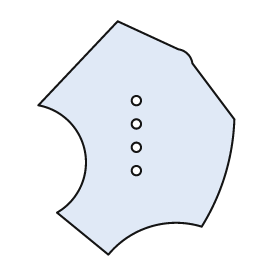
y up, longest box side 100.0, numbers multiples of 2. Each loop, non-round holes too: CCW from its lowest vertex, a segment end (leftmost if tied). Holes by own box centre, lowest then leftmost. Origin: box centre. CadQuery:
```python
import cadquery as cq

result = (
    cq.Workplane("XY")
    .moveTo(-12.0, -50.0)
    .threePointArc((6.0, -38.0), (28.0, -38.0))
    .threePointArc((38.0, -16.0), (42.0, 8.0))
    .lineTo(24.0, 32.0)
    .threePointArc((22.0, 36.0), (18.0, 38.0))
    .lineTo(-8.0, 50.0)
    .lineTo(-42.0, 14.0)
    .threePointArc((-22.0, -6.0), (-34.0, -32.0))
    .close()
    .moveTo(0.0, -14.0)
    .circle(2.0)
    .moveTo(0.0, -4.0)
    .circle(2.0)
    .moveTo(0.0, 6.0)
    .circle(2.0)
    .moveTo(0.0, 16.0)
    .circle(2.0)
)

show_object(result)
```